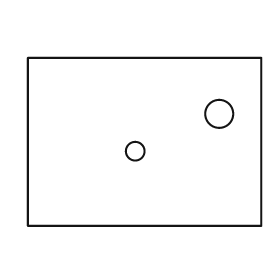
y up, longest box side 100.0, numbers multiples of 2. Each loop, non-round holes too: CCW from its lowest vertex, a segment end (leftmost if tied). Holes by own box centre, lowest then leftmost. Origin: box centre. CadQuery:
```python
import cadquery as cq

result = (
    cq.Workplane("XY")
    .moveTo(-50.0, -36.0)
    .lineTo(50.0, -36.0)
    .lineTo(50.0, 36.0)
    .lineTo(-50.0, 36.0)
    .close()
    .moveTo(-4.0, -4.0)
    .circle(4.0)
    .moveTo(32.0, 12.0)
    .circle(6.0)
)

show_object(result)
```